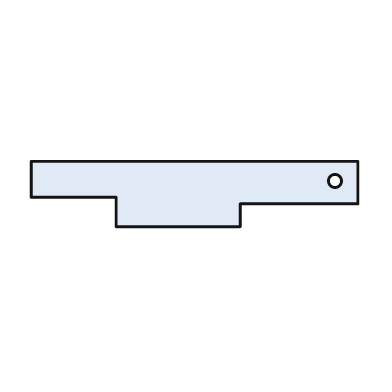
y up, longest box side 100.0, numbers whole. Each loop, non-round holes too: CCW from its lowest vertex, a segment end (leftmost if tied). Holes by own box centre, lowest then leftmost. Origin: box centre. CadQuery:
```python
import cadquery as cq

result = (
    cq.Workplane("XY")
    .moveTo(-24.0, -10.0)
    .lineTo(14.0, -10.0)
    .lineTo(14.0, -3.0)
    .lineTo(50.0, -3.0)
    .lineTo(50.0, 10.0)
    .lineTo(-50.0, 10.0)
    .lineTo(-50.0, -1.0)
    .lineTo(-24.0, -1.0)
    .close()
    .moveTo(43.0, 4.0)
    .circle(2.0)
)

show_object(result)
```